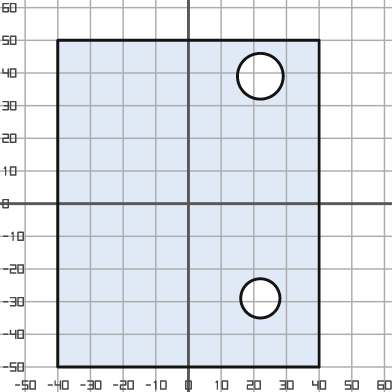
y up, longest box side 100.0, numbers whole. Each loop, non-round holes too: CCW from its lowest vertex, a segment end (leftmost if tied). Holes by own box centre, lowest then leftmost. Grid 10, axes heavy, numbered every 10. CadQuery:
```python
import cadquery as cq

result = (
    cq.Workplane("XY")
    .moveTo(-40.0, -50.0)
    .lineTo(40.0, -50.0)
    .lineTo(40.0, 50.0)
    .lineTo(-40.0, 50.0)
    .close()
    .moveTo(22.0, -29.0)
    .circle(6.0)
    .moveTo(22.0, 39.0)
    .circle(7.0)
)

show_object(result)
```